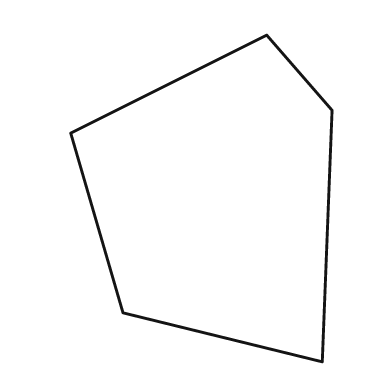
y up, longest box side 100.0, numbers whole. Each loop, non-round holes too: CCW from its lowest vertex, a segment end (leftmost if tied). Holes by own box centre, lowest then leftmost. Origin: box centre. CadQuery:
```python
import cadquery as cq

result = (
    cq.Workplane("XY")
    .moveTo(37.0, -50.0)
    .lineTo(40.0, 27.0)
    .lineTo(20.0, 50.0)
    .lineTo(-40.0, 20.0)
    .lineTo(-24.0, -35.0)
    .close()
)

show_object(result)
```